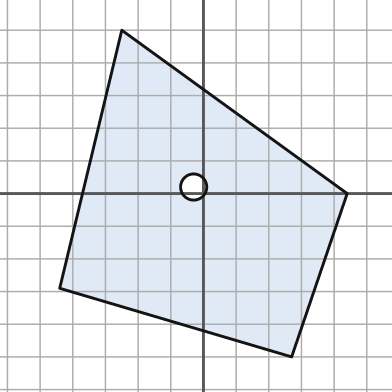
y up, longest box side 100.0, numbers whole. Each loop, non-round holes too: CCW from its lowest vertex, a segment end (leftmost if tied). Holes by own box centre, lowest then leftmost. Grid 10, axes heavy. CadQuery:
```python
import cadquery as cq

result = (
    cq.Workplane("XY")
    .moveTo(27.0, -50.0)
    .lineTo(44.0, 0.0)
    .lineTo(-25.0, 50.0)
    .lineTo(-44.0, -29.0)
    .close()
    .moveTo(-3.0, 2.0)
    .circle(4.0)
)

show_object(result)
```